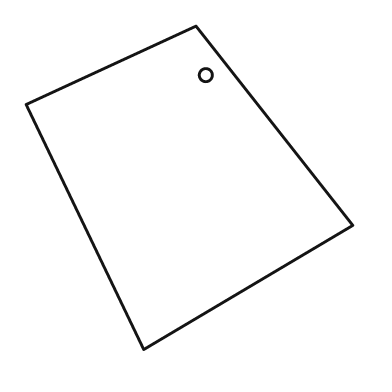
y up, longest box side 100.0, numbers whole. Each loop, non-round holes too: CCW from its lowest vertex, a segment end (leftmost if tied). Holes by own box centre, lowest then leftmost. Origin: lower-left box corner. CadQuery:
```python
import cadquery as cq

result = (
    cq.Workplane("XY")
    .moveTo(36.0, 0.0)
    .lineTo(100.0, 38.0)
    .lineTo(52.0, 99.0)
    .lineTo(0.0, 75.0)
    .close()
    .moveTo(55.0, 84.0)
    .circle(2.0)
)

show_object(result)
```